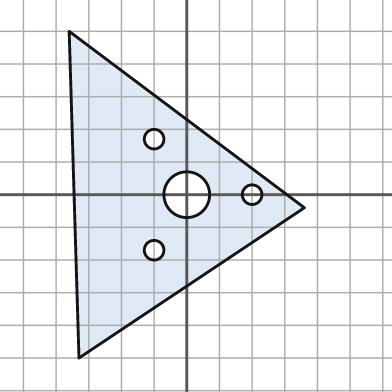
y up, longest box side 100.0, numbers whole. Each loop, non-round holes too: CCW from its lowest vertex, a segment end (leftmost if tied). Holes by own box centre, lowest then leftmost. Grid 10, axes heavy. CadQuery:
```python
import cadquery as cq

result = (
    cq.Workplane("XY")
    .moveTo(-33.0, -50.0)
    .lineTo(36.0, -4.0)
    .lineTo(-36.0, 50.0)
    .close()
    .moveTo(-10.0, -17.0)
    .circle(3.0)
    .moveTo(0.0, 0.0)
    .circle(7.0)
    .moveTo(20.0, 0.0)
    .circle(3.0)
    .moveTo(-10.0, 17.0)
    .circle(3.0)
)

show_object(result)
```